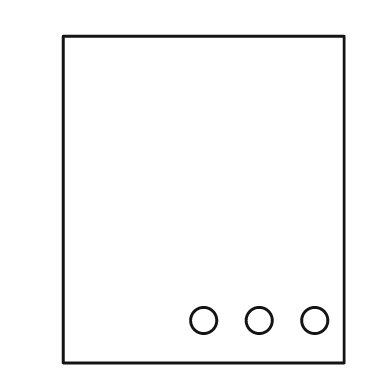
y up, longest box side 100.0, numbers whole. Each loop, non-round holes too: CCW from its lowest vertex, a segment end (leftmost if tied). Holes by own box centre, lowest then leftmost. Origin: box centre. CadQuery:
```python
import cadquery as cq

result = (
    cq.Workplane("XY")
    .moveTo(-43.0, -50.0)
    .lineTo(43.0, -50.0)
    .lineTo(43.0, 50.0)
    .lineTo(-43.0, 50.0)
    .close()
    .moveTo(0.0, -37.0)
    .circle(4.0)
    .moveTo(17.0, -37.0)
    .circle(4.0)
    .moveTo(34.0, -37.0)
    .circle(4.0)
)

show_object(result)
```